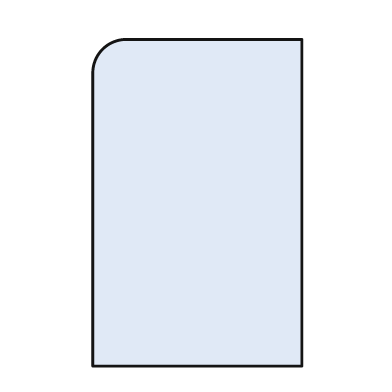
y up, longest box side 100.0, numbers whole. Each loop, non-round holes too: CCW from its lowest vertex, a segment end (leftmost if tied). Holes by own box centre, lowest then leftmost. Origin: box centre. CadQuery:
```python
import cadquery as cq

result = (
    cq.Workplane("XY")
    .moveTo(-32.0, -50.0)
    .lineTo(32.0, -50.0)
    .lineTo(32.0, 50.0)
    .lineTo(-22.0, 50.0)
    .threePointArc((-29.0, 47.0), (-32.0, 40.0))
    .close()
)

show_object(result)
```